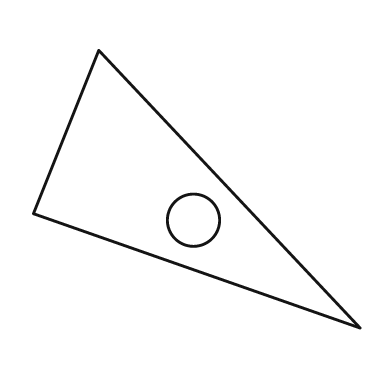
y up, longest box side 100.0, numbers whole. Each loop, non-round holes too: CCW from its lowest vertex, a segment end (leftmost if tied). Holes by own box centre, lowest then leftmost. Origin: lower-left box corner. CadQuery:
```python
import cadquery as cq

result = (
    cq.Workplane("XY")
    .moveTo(100.0, 0.0)
    .lineTo(20.0, 85.0)
    .lineTo(0.0, 35.0)
    .close()
    .moveTo(49.0, 33.0)
    .circle(8.0)
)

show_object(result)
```